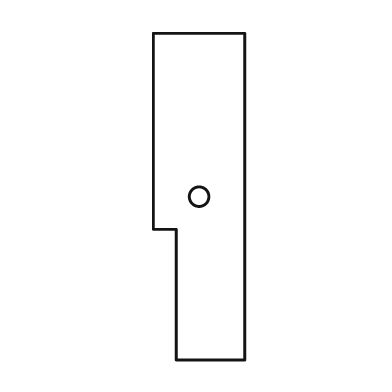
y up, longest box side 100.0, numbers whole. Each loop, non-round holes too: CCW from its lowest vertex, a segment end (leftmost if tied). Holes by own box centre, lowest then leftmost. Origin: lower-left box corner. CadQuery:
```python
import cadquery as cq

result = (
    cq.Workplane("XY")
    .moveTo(7.0, 0.0)
    .lineTo(28.0, 0.0)
    .lineTo(28.0, 100.0)
    .lineTo(0.0, 100.0)
    .lineTo(0.0, 40.0)
    .lineTo(7.0, 40.0)
    .close()
    .moveTo(14.0, 50.0)
    .circle(3.0)
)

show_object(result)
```